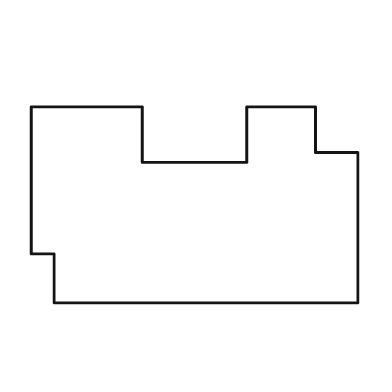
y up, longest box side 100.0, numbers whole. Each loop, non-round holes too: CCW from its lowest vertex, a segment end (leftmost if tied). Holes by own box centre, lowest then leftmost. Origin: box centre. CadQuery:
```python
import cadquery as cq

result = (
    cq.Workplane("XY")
    .moveTo(-43.0, -30.0)
    .lineTo(50.0, -30.0)
    .lineTo(50.0, 16.0)
    .lineTo(37.0, 16.0)
    .lineTo(37.0, 30.0)
    .lineTo(16.0, 30.0)
    .lineTo(16.0, 13.0)
    .lineTo(-16.0, 13.0)
    .lineTo(-16.0, 30.0)
    .lineTo(-50.0, 30.0)
    .lineTo(-50.0, -15.0)
    .lineTo(-43.0, -15.0)
    .close()
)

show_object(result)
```